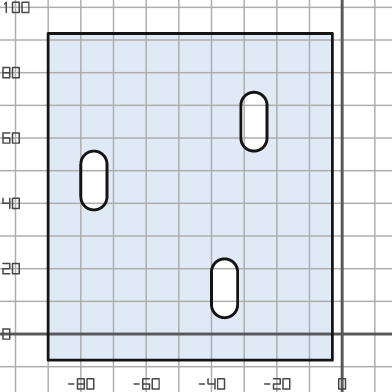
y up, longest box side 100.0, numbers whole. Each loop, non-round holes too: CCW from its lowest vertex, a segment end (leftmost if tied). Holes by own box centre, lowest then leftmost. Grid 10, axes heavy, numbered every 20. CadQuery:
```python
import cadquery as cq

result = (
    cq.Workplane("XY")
    .moveTo(-90.0, -8.0)
    .lineTo(-3.0, -8.0)
    .lineTo(-3.0, 92.0)
    .lineTo(-90.0, 92.0)
    .close()
    .moveTo(-40.0, 9.0)
    .threePointArc((-36.0, 5.0), (-32.0, 9.0))
    .lineTo(-32.0, 19.0)
    .threePointArc((-36.0, 23.0), (-40.0, 19.0))
    .close()
    .moveTo(-80.0, 42.0)
    .threePointArc((-76.0, 38.0), (-72.0, 42.0))
    .lineTo(-72.0, 52.0)
    .threePointArc((-76.0, 56.0), (-80.0, 52.0))
    .close()
    .moveTo(-31.0, 60.0)
    .threePointArc((-27.0, 56.0), (-23.0, 60.0))
    .lineTo(-23.0, 70.0)
    .threePointArc((-27.0, 74.0), (-31.0, 70.0))
    .close()
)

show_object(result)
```